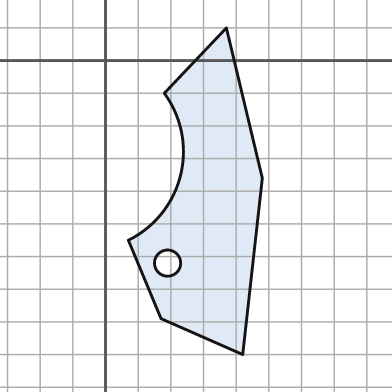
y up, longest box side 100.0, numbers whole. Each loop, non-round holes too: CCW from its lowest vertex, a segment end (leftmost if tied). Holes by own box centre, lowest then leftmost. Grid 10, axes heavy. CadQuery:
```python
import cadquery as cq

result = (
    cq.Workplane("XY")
    .moveTo(42.0, -90.0)
    .lineTo(48.0, -36.0)
    .lineTo(37.0, 10.0)
    .lineTo(18.0, -10.0)
    .threePointArc((23.0, -35.0), (7.0, -55.0))
    .lineTo(17.0, -79.0)
    .close()
    .moveTo(19.0, -62.0)
    .circle(4.0)
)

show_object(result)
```